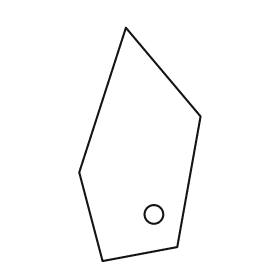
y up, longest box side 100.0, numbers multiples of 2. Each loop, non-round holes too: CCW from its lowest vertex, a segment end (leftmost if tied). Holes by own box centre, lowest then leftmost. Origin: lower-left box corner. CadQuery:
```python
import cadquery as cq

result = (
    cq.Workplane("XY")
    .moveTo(10.0, 0.0)
    .lineTo(42.0, 6.0)
    .lineTo(52.0, 62.0)
    .lineTo(20.0, 100.0)
    .lineTo(0.0, 38.0)
    .close()
    .moveTo(32.0, 20.0)
    .circle(4.0)
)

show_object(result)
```